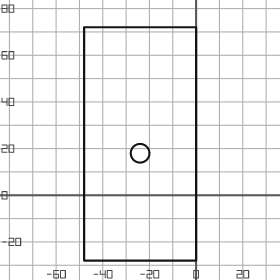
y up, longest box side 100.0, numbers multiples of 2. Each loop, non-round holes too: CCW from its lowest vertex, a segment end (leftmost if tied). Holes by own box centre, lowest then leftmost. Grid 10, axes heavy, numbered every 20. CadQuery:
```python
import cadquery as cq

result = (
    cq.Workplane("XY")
    .moveTo(-48.0, -28.0)
    .lineTo(0.0, -28.0)
    .lineTo(0.0, 72.0)
    .lineTo(-48.0, 72.0)
    .close()
    .moveTo(-24.0, 18.0)
    .circle(4.0)
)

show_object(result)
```